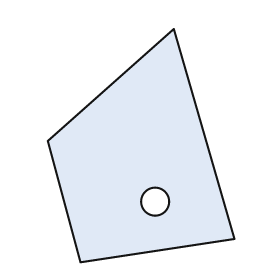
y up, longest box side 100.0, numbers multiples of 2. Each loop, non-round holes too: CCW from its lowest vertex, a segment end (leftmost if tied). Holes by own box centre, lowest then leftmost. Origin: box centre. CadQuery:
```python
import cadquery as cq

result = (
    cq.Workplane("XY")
    .moveTo(-26.0, -50.0)
    .lineTo(40.0, -40.0)
    .lineTo(14.0, 50.0)
    .lineTo(-40.0, 2.0)
    .close()
    .moveTo(6.0, -24.0)
    .circle(6.0)
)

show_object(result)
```